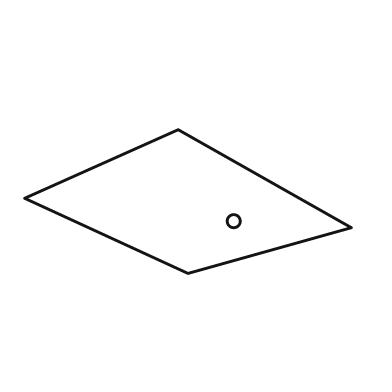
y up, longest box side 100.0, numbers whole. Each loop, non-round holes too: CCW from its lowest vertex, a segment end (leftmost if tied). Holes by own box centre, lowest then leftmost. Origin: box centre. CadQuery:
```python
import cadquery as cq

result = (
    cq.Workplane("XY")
    .moveTo(0.0, -22.0)
    .lineTo(50.0, -8.0)
    .lineTo(-3.0, 22.0)
    .lineTo(-50.0, 1.0)
    .close()
    .moveTo(14.0, -6.0)
    .circle(2.0)
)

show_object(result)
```